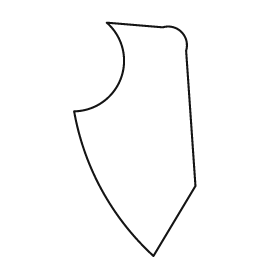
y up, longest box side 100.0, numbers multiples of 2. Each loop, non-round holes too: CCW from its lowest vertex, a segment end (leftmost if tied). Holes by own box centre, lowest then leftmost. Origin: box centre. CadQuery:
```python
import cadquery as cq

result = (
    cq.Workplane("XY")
    .moveTo(8.0, -50.0)
    .lineTo(26.0, -20.0)
    .lineTo(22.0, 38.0)
    .threePointArc((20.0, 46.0), (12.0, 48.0))
    .lineTo(-12.0, 50.0)
    .threePointArc((-6.0, 26.0), (-26.0, 12.0))
    .threePointArc((-14.0, -22.0), (8.0, -50.0))
    .close()
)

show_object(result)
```